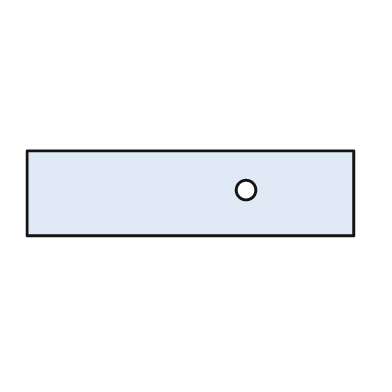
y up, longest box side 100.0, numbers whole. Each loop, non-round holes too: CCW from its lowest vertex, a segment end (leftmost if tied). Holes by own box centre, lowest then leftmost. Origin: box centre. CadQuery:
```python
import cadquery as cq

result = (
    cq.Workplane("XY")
    .moveTo(-50.0, -13.0)
    .lineTo(50.0, -13.0)
    .lineTo(50.0, 13.0)
    .lineTo(-50.0, 13.0)
    .close()
    .moveTo(17.0, 1.0)
    .circle(3.0)
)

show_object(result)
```